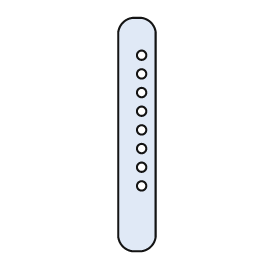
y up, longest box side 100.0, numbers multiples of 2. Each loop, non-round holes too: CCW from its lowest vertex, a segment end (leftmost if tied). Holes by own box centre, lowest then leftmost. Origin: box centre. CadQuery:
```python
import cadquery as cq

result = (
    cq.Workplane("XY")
    .moveTo(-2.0, -50.0)
    .lineTo(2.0, -50.0)
    .threePointArc((6.0, -48.0), (8.0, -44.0))
    .lineTo(8.0, 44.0)
    .threePointArc((6.0, 48.0), (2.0, 50.0))
    .lineTo(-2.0, 50.0)
    .threePointArc((-6.0, 48.0), (-8.0, 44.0))
    .lineTo(-8.0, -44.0)
    .threePointArc((-6.0, -48.0), (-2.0, -50.0))
    .close()
    .moveTo(2.0, -22.0)
    .circle(2.0)
    .moveTo(2.0, -14.0)
    .circle(2.0)
    .moveTo(2.0, -6.0)
    .circle(2.0)
    .moveTo(2.0, 2.0)
    .circle(2.0)
    .moveTo(2.0, 10.0)
    .circle(2.0)
    .moveTo(2.0, 18.0)
    .circle(2.0)
    .moveTo(2.0, 26.0)
    .circle(2.0)
    .moveTo(2.0, 34.0)
    .circle(2.0)
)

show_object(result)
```